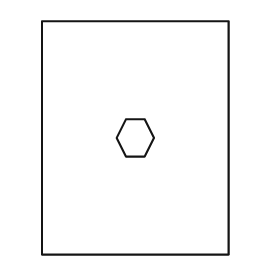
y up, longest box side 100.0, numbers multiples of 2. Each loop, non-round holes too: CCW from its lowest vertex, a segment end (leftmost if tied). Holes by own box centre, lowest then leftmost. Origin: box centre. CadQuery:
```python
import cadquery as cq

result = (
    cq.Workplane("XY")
    .moveTo(-40.0, -50.0)
    .lineTo(40.0, -50.0)
    .lineTo(40.0, 50.0)
    .lineTo(-40.0, 50.0)
    .close()
    .moveTo(-4.0, -8.0)
    .lineTo(4.0, -8.0)
    .lineTo(8.0, 0.0)
    .lineTo(4.0, 8.0)
    .lineTo(-4.0, 8.0)
    .lineTo(-8.0, 0.0)
    .close()
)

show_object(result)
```